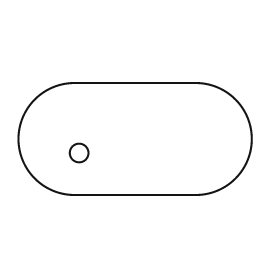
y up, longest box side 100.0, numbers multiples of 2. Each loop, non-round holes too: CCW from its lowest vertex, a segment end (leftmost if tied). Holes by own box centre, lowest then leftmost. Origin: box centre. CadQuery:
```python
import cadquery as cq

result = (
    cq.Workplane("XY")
    .moveTo(-26.0, -24.0)
    .lineTo(26.0, -24.0)
    .threePointArc((50.0, 0.0), (26.0, 24.0))
    .lineTo(-26.0, 24.0)
    .threePointArc((-50.0, 0.0), (-26.0, -24.0))
    .close()
    .moveTo(-24.0, -6.0)
    .circle(4.0)
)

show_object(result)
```